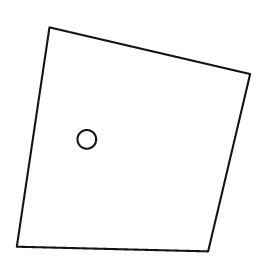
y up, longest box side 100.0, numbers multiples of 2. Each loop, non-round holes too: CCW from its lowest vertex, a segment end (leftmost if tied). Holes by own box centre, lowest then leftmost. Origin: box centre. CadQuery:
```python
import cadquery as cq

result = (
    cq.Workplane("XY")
    .moveTo(32.0, -48.0)
    .lineTo(50.0, 28.0)
    .lineTo(-36.0, 48.0)
    .lineTo(-50.0, -46.0)
    .close()
    .moveTo(-20.0, 0.0)
    .circle(4.0)
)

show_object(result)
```